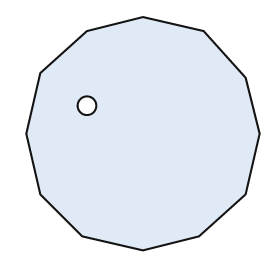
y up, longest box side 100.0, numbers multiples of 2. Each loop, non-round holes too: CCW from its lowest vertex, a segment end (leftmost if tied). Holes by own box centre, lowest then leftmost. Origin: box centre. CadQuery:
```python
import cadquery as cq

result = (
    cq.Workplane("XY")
    .moveTo(0.0, -50.0)
    .lineTo(24.0, -44.0)
    .lineTo(44.0, -26.0)
    .lineTo(50.0, 0.0)
    .lineTo(44.0, 24.0)
    .lineTo(26.0, 44.0)
    .lineTo(0.0, 50.0)
    .lineTo(-24.0, 44.0)
    .lineTo(-44.0, 26.0)
    .lineTo(-50.0, 0.0)
    .lineTo(-44.0, -26.0)
    .lineTo(-26.0, -44.0)
    .close()
    .moveTo(-24.0, 12.0)
    .circle(4.0)
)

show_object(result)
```